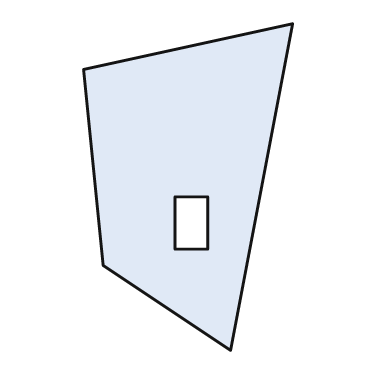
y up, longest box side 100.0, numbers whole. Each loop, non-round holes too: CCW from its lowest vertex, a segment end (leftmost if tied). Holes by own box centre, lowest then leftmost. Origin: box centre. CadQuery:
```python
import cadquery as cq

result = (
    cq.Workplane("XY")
    .moveTo(13.0, -50.0)
    .lineTo(32.0, 50.0)
    .lineTo(-32.0, 36.0)
    .lineTo(-26.0, -24.0)
    .close()
    .moveTo(-4.0, -19.0)
    .lineTo(6.0, -19.0)
    .lineTo(6.0, -3.0)
    .lineTo(-4.0, -3.0)
    .close()
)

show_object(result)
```